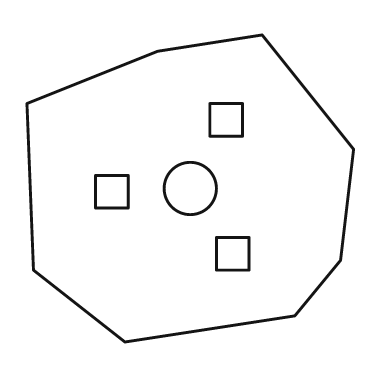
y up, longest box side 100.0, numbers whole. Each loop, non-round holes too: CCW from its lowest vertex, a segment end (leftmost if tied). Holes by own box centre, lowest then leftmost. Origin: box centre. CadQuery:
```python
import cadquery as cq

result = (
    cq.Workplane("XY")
    .moveTo(-20.0, -47.0)
    .lineTo(32.0, -39.0)
    .lineTo(46.0, -22.0)
    .lineTo(50.0, 12.0)
    .lineTo(22.0, 47.0)
    .lineTo(-10.0, 42.0)
    .lineTo(-50.0, 26.0)
    .lineTo(-48.0, -25.0)
    .close()
    .moveTo(8.0, -25.0)
    .lineTo(18.0, -25.0)
    .lineTo(18.0, -15.0)
    .lineTo(8.0, -15.0)
    .close()
    .moveTo(-29.0, -6.0)
    .lineTo(-19.0, -6.0)
    .lineTo(-19.0, 4.0)
    .lineTo(-29.0, 4.0)
    .close()
    .moveTo(0.0, 0.0)
    .circle(8.0)
    .moveTo(6.0, 16.0)
    .lineTo(16.0, 16.0)
    .lineTo(16.0, 26.0)
    .lineTo(6.0, 26.0)
    .close()
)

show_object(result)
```